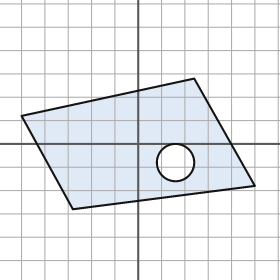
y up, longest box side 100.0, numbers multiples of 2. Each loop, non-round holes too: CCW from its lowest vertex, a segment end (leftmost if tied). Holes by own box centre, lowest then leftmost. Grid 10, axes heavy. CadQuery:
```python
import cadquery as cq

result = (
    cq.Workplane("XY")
    .moveTo(-28.0, -28.0)
    .lineTo(50.0, -18.0)
    .lineTo(24.0, 28.0)
    .lineTo(-50.0, 12.0)
    .close()
    .moveTo(16.0, -8.0)
    .circle(8.0)
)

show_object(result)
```